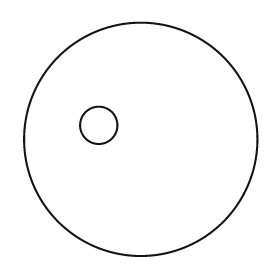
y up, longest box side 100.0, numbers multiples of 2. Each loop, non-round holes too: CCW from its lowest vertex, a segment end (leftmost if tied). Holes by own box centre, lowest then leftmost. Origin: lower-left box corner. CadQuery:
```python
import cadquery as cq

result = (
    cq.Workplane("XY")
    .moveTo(50.0, 50.0)
    .circle(50.0)
    .moveTo(32.0, 56.0)
    .circle(8.0)
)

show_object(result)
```